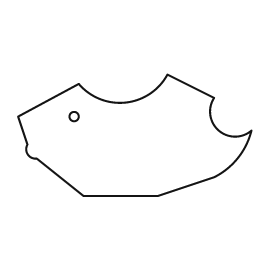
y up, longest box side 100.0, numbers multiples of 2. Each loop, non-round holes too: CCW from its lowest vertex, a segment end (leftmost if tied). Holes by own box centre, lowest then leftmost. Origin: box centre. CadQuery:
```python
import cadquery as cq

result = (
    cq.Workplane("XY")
    .moveTo(-22.0, -26.0)
    .lineTo(10.0, -26.0)
    .lineTo(34.0, -18.0)
    .threePointArc((44.0, -10.0), (50.0, 2.0))
    .threePointArc((36.0, 2.0), (34.0, 16.0))
    .lineTo(14.0, 26.0)
    .threePointArc((-4.0, 14.0), (-24.0, 22.0))
    .lineTo(-50.0, 8.0)
    .lineTo(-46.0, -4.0)
    .threePointArc((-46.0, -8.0), (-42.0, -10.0))
    .close()
    .moveTo(-26.0, 8.0)
    .circle(2.0)
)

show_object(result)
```